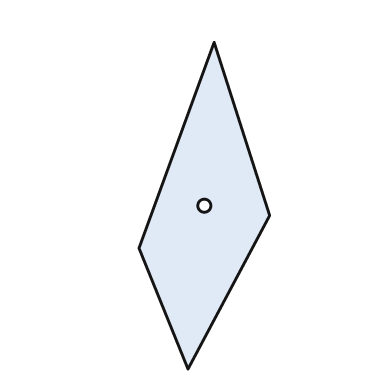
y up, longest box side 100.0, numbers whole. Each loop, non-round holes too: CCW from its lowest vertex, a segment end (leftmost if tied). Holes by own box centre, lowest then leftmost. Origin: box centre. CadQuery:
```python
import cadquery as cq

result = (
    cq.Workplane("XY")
    .moveTo(-5.0, -50.0)
    .lineTo(20.0, -3.0)
    .lineTo(3.0, 50.0)
    .lineTo(-20.0, -13.0)
    .close()
    .moveTo(0.0, 0.0)
    .circle(2.0)
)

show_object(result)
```